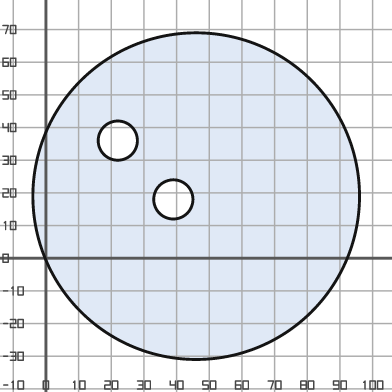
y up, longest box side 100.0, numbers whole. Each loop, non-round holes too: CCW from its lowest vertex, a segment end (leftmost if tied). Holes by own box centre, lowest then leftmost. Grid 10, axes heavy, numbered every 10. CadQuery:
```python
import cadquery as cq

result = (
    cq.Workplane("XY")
    .moveTo(46.0, 19.0)
    .circle(50.0)
    .moveTo(39.0, 18.0)
    .circle(6.0)
    .moveTo(22.0, 36.0)
    .circle(6.0)
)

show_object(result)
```